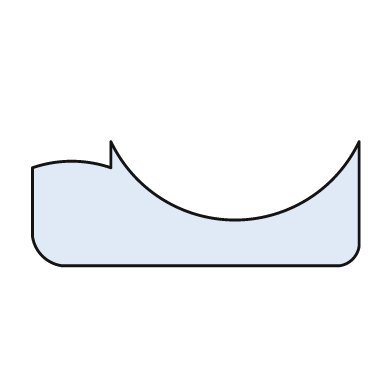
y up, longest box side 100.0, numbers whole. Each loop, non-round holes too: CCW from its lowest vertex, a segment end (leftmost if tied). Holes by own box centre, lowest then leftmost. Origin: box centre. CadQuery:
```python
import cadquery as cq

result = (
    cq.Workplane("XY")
    .moveTo(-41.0, -19.0)
    .lineTo(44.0, -19.0)
    .threePointArc((48.0, -17.0), (50.0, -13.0))
    .lineTo(50.0, 19.0)
    .threePointArc((12.0, -5.0), (-26.0, 19.0))
    .lineTo(-26.0, 11.0)
    .threePointArc((-38.0, 13.0), (-50.0, 11.0))
    .lineTo(-50.0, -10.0)
    .threePointArc((-47.0, -16.0), (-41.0, -19.0))
    .close()
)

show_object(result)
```